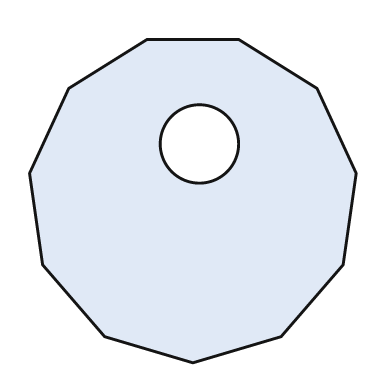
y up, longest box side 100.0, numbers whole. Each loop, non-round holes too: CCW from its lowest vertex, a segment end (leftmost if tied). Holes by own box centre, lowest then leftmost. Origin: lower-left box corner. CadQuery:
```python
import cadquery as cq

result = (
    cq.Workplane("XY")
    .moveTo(50.0, 0.0)
    .lineTo(77.0, 8.0)
    .lineTo(96.0, 30.0)
    .lineTo(100.0, 58.0)
    .lineTo(88.0, 84.0)
    .lineTo(64.0, 99.0)
    .lineTo(36.0, 99.0)
    .lineTo(12.0, 84.0)
    .lineTo(0.0, 58.0)
    .lineTo(4.0, 30.0)
    .lineTo(23.0, 8.0)
    .close()
    .moveTo(52.0, 67.0)
    .circle(12.0)
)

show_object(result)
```